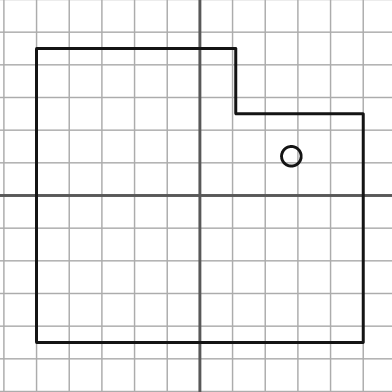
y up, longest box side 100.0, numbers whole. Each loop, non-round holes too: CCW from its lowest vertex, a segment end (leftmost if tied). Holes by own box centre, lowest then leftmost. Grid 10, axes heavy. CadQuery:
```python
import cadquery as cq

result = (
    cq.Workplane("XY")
    .moveTo(-50.0, -45.0)
    .lineTo(50.0, -45.0)
    .lineTo(50.0, 25.0)
    .lineTo(11.0, 25.0)
    .lineTo(11.0, 45.0)
    .lineTo(-50.0, 45.0)
    .close()
    .moveTo(28.0, 12.0)
    .circle(3.0)
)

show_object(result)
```